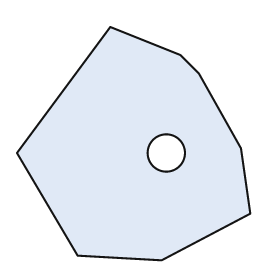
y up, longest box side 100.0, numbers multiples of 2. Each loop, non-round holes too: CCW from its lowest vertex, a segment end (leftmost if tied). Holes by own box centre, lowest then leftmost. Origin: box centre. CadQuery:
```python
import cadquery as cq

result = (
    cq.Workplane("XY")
    .moveTo(12.0, -50.0)
    .lineTo(50.0, -30.0)
    .lineTo(46.0, -2.0)
    .lineTo(28.0, 30.0)
    .lineTo(20.0, 38.0)
    .lineTo(-10.0, 50.0)
    .lineTo(-50.0, -4.0)
    .lineTo(-24.0, -48.0)
    .close()
    .moveTo(14.0, -4.0)
    .circle(8.0)
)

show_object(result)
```